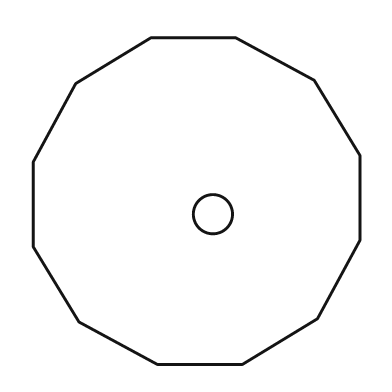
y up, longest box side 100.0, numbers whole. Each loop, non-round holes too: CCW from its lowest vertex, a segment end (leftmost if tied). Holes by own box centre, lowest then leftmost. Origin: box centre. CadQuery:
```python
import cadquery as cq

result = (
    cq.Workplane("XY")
    .moveTo(-12.0, -50.0)
    .lineTo(14.0, -50.0)
    .lineTo(37.0, -36.0)
    .lineTo(50.0, -12.0)
    .lineTo(50.0, 14.0)
    .lineTo(36.0, 37.0)
    .lineTo(12.0, 50.0)
    .lineTo(-14.0, 50.0)
    .lineTo(-37.0, 36.0)
    .lineTo(-50.0, 12.0)
    .lineTo(-50.0, -14.0)
    .lineTo(-36.0, -37.0)
    .close()
    .moveTo(5.0, -4.0)
    .circle(6.0)
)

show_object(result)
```